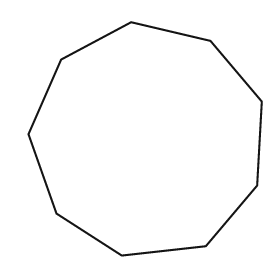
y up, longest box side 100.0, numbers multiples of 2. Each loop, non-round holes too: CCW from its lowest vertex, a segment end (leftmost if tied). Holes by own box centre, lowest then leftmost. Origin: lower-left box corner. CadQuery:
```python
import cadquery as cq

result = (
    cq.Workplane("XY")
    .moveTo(40.0, 0.0)
    .lineTo(76.0, 4.0)
    .lineTo(98.0, 30.0)
    .lineTo(100.0, 66.0)
    .lineTo(78.0, 92.0)
    .lineTo(44.0, 100.0)
    .lineTo(14.0, 84.0)
    .lineTo(0.0, 52.0)
    .lineTo(12.0, 18.0)
    .close()
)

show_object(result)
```